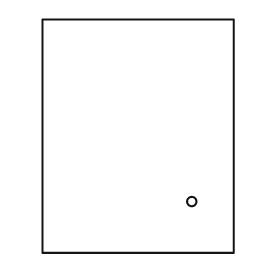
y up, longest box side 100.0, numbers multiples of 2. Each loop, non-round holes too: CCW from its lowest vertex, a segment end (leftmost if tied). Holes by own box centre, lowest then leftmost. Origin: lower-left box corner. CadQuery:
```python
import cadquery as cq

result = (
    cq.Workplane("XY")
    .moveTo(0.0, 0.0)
    .lineTo(82.0, 0.0)
    .lineTo(82.0, 100.0)
    .lineTo(0.0, 100.0)
    .close()
    .moveTo(64.0, 22.0)
    .circle(2.0)
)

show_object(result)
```